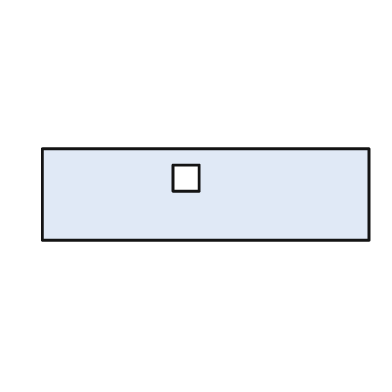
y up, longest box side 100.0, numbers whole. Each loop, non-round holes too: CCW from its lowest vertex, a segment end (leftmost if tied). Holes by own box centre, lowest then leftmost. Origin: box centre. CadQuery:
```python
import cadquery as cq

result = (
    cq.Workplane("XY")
    .moveTo(-50.0, -14.0)
    .lineTo(50.0, -14.0)
    .lineTo(50.0, 14.0)
    .lineTo(-50.0, 14.0)
    .close()
    .moveTo(-10.0, 1.0)
    .lineTo(-2.0, 1.0)
    .lineTo(-2.0, 9.0)
    .lineTo(-10.0, 9.0)
    .close()
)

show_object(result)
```